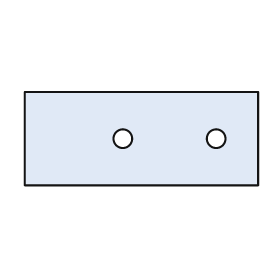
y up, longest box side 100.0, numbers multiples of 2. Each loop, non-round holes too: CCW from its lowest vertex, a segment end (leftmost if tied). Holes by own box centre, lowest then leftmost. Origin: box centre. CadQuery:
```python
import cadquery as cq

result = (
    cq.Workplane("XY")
    .moveTo(-50.0, -20.0)
    .lineTo(50.0, -20.0)
    .lineTo(50.0, 20.0)
    .lineTo(-50.0, 20.0)
    .close()
    .moveTo(-8.0, 0.0)
    .circle(4.0)
    .moveTo(32.0, 0.0)
    .circle(4.0)
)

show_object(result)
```